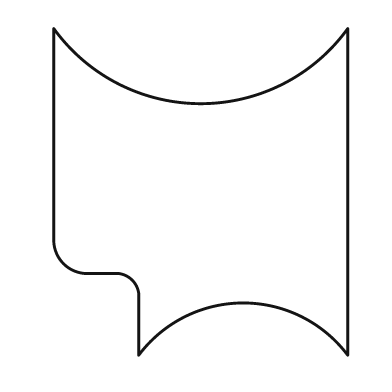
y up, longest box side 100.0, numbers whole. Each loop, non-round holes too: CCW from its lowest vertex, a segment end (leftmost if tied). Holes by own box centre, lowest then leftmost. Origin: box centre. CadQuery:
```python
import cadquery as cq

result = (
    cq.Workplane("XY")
    .moveTo(-19.0, -50.0)
    .threePointArc((13.0, -34.0), (45.0, -50.0))
    .lineTo(45.0, 50.0)
    .threePointArc((0.0, 27.0), (-45.0, 50.0))
    .lineTo(-45.0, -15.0)
    .threePointArc((-42.0, -22.0), (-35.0, -25.0))
    .lineTo(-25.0, -25.0)
    .threePointArc((-21.0, -27.0), (-19.0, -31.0))
    .close()
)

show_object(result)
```